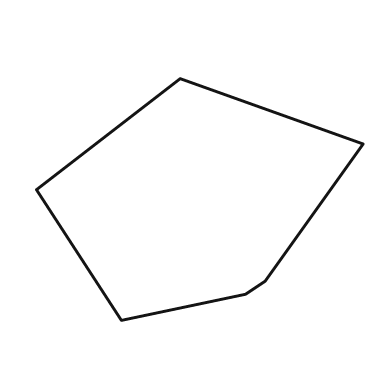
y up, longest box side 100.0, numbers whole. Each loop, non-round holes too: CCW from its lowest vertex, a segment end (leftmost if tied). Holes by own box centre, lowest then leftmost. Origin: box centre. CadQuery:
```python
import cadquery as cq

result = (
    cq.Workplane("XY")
    .moveTo(-24.0, -37.0)
    .lineTo(14.0, -29.0)
    .lineTo(20.0, -25.0)
    .lineTo(50.0, 17.0)
    .lineTo(-6.0, 37.0)
    .lineTo(-50.0, 3.0)
    .close()
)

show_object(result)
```